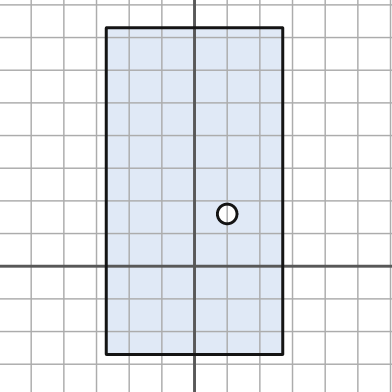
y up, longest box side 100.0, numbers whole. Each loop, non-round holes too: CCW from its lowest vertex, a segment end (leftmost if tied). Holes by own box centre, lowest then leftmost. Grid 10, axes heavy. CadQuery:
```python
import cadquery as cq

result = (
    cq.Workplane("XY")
    .moveTo(-27.0, -27.0)
    .lineTo(27.0, -27.0)
    .lineTo(27.0, 73.0)
    .lineTo(-27.0, 73.0)
    .close()
    .moveTo(10.0, 16.0)
    .circle(3.0)
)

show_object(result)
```